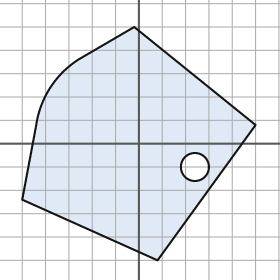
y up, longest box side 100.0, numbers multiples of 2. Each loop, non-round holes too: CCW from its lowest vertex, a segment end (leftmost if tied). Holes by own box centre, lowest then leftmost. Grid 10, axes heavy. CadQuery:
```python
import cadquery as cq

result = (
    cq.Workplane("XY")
    .moveTo(8.0, -50.0)
    .lineTo(50.0, 8.0)
    .lineTo(-2.0, 50.0)
    .lineTo(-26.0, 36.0)
    .threePointArc((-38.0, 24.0), (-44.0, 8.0))
    .lineTo(-50.0, -24.0)
    .close()
    .moveTo(24.0, -10.0)
    .circle(6.0)
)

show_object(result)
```